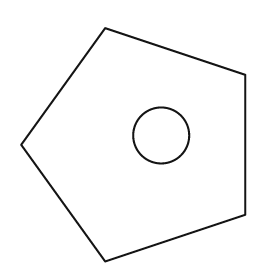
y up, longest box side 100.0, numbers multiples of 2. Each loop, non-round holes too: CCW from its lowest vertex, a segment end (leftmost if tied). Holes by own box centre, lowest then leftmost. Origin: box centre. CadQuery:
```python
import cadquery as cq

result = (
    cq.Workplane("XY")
    .moveTo(-12.0, -50.0)
    .lineTo(48.0, -30.0)
    .lineTo(48.0, 30.0)
    .lineTo(-12.0, 50.0)
    .lineTo(-48.0, 0.0)
    .close()
    .moveTo(12.0, 4.0)
    .circle(12.0)
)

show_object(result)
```